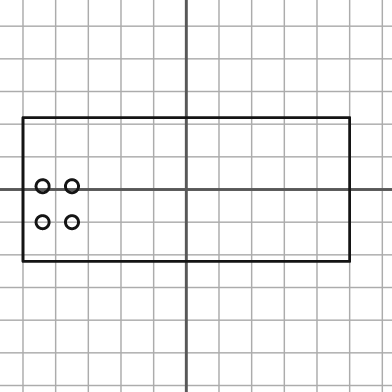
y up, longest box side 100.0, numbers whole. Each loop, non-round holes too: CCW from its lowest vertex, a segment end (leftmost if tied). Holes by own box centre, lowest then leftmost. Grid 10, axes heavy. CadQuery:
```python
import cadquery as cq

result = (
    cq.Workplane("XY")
    .moveTo(-50.0, -22.0)
    .lineTo(50.0, -22.0)
    .lineTo(50.0, 22.0)
    .lineTo(-50.0, 22.0)
    .close()
    .moveTo(-44.0, -10.0)
    .circle(2.0)
    .moveTo(-35.0, -10.0)
    .circle(2.0)
    .moveTo(-44.0, 1.0)
    .circle(2.0)
    .moveTo(-35.0, 1.0)
    .circle(2.0)
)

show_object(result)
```